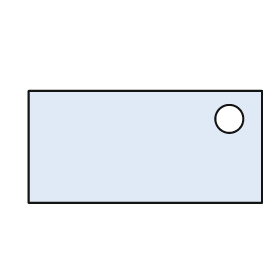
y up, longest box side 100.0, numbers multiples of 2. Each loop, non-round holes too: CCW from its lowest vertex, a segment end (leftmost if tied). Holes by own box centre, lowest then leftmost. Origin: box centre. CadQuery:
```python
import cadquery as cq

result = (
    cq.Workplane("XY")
    .moveTo(-50.0, -24.0)
    .lineTo(50.0, -24.0)
    .lineTo(50.0, 24.0)
    .lineTo(-50.0, 24.0)
    .close()
    .moveTo(36.0, 12.0)
    .circle(6.0)
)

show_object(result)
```